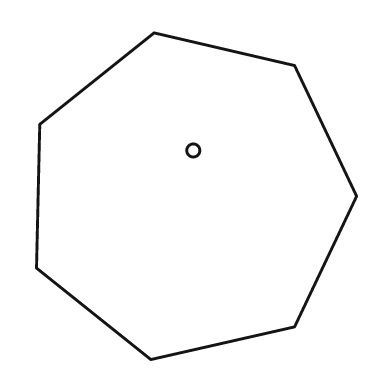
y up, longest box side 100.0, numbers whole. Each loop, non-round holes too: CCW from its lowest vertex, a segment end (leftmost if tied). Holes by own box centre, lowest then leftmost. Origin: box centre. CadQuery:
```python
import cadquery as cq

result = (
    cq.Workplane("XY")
    .moveTo(-14.0, -50.0)
    .lineTo(30.0, -40.0)
    .lineTo(49.0, 0.0)
    .lineTo(30.0, 40.0)
    .lineTo(-13.0, 50.0)
    .lineTo(-48.0, 22.0)
    .lineTo(-49.0, -22.0)
    .close()
    .moveTo(-1.0, 14.0)
    .circle(2.0)
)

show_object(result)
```